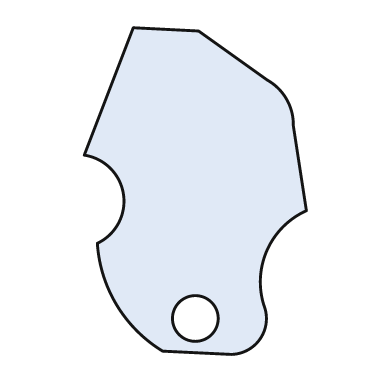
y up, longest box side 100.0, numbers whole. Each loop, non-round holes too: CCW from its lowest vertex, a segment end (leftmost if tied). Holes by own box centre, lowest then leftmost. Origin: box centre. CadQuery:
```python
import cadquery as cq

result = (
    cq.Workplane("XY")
    .moveTo(11.0, -50.0)
    .threePointArc((20.0, -45.0), (21.0, -35.0))
    .threePointArc((22.0, -18.0), (34.0, -6.0))
    .lineTo(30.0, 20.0)
    .threePointArc((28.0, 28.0), (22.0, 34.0))
    .lineTo(1.0, 49.0)
    .lineTo(-19.0, 50.0)
    .lineTo(-34.0, 11.0)
    .threePointArc((-22.0, -1.0), (-30.0, -16.0))
    .threePointArc((-24.0, -35.0), (-10.0, -49.0))
    .close()
    .moveTo(0.0, -39.0)
    .circle(7.0)
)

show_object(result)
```